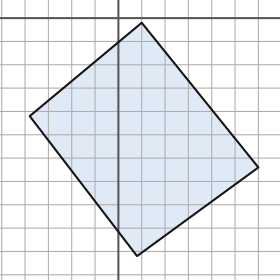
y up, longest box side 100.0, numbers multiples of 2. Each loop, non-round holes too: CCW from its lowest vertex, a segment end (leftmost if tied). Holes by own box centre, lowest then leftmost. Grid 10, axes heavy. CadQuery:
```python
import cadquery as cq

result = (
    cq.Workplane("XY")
    .moveTo(8.0, -102.0)
    .lineTo(60.0, -64.0)
    .lineTo(10.0, -2.0)
    .lineTo(-38.0, -42.0)
    .close()
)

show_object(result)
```